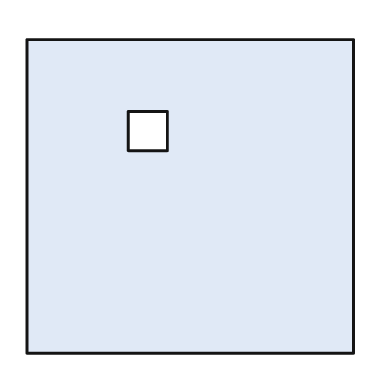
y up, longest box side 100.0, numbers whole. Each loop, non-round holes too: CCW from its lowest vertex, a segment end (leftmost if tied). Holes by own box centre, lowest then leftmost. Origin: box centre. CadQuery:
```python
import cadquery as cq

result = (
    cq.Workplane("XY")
    .moveTo(-50.0, -48.0)
    .lineTo(50.0, -48.0)
    .lineTo(50.0, 48.0)
    .lineTo(-50.0, 48.0)
    .close()
    .moveTo(-19.0, 14.0)
    .lineTo(-7.0, 14.0)
    .lineTo(-7.0, 26.0)
    .lineTo(-19.0, 26.0)
    .close()
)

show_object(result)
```